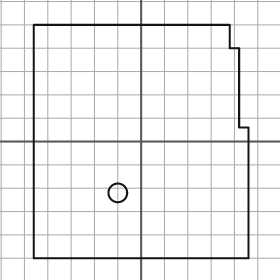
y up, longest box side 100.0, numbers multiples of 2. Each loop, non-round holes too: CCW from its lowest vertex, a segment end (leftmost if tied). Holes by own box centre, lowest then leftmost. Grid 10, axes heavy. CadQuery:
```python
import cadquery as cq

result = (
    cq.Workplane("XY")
    .moveTo(-46.0, -50.0)
    .lineTo(46.0, -50.0)
    .lineTo(46.0, 6.0)
    .lineTo(42.0, 6.0)
    .lineTo(42.0, 40.0)
    .lineTo(38.0, 40.0)
    .lineTo(38.0, 50.0)
    .lineTo(-46.0, 50.0)
    .close()
    .moveTo(-10.0, -22.0)
    .circle(4.0)
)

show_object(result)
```